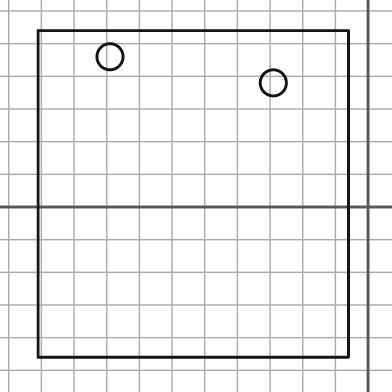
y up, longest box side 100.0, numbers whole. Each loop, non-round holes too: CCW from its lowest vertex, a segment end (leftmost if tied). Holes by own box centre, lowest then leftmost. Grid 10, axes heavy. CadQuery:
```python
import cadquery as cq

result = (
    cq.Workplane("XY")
    .moveTo(-101.0, -46.0)
    .lineTo(-6.0, -46.0)
    .lineTo(-6.0, 54.0)
    .lineTo(-101.0, 54.0)
    .close()
    .moveTo(-29.0, 38.0)
    .circle(4.0)
    .moveTo(-79.0, 46.0)
    .circle(4.0)
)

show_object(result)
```